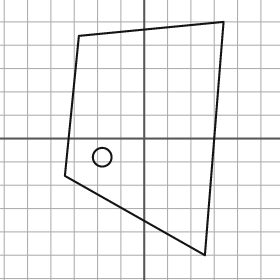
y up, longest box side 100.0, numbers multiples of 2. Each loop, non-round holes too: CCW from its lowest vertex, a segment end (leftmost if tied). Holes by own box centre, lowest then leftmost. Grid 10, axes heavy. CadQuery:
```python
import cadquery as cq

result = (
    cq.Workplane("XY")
    .moveTo(26.0, -50.0)
    .lineTo(34.0, 50.0)
    .lineTo(-28.0, 44.0)
    .lineTo(-34.0, -16.0)
    .close()
    .moveTo(-18.0, -8.0)
    .circle(4.0)
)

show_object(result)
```